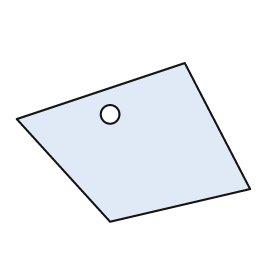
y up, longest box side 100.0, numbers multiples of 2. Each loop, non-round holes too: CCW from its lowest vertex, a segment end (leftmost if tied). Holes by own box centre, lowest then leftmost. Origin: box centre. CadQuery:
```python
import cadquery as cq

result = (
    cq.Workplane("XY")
    .moveTo(-10.0, -34.0)
    .lineTo(50.0, -20.0)
    .lineTo(22.0, 34.0)
    .lineTo(-50.0, 10.0)
    .close()
    .moveTo(-10.0, 12.0)
    .circle(4.0)
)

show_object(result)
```